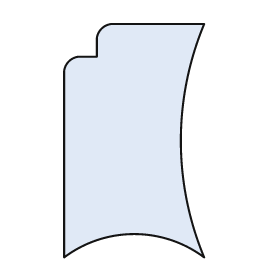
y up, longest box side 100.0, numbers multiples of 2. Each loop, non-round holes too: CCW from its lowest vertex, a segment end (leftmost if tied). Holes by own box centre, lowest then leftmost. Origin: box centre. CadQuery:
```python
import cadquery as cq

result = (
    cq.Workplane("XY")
    .moveTo(-30.0, -50.0)
    .threePointArc((0.0, -40.0), (30.0, -50.0))
    .threePointArc((20.0, 0.0), (30.0, 50.0))
    .lineTo(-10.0, 50.0)
    .threePointArc((-14.0, 48.0), (-16.0, 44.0))
    .lineTo(-16.0, 36.0)
    .lineTo(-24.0, 36.0)
    .threePointArc((-28.0, 34.0), (-30.0, 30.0))
    .close()
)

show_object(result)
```